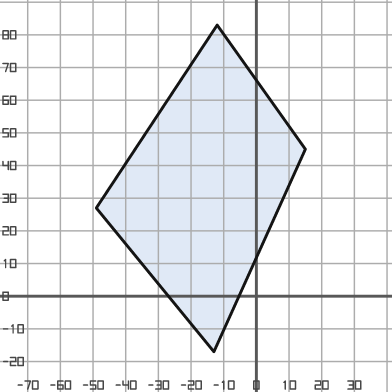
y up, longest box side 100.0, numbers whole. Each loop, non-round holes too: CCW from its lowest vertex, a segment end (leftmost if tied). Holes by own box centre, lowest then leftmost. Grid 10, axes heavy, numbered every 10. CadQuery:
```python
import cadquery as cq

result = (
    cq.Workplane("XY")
    .moveTo(-13.0, -17.0)
    .lineTo(15.0, 45.0)
    .lineTo(-12.0, 83.0)
    .lineTo(-49.0, 27.0)
    .close()
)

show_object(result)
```